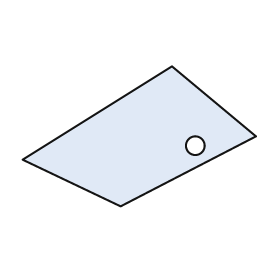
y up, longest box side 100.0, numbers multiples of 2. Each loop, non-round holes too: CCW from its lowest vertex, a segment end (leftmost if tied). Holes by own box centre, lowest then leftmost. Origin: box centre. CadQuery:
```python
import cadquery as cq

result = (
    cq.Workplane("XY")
    .moveTo(-8.0, -30.0)
    .lineTo(50.0, 0.0)
    .lineTo(14.0, 30.0)
    .lineTo(-50.0, -10.0)
    .close()
    .moveTo(24.0, -4.0)
    .circle(4.0)
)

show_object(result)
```